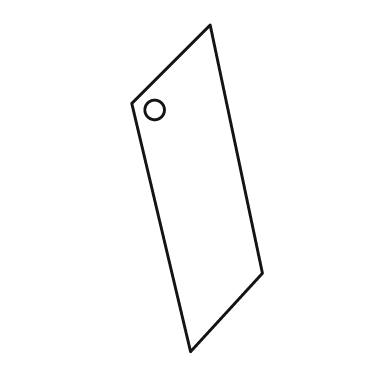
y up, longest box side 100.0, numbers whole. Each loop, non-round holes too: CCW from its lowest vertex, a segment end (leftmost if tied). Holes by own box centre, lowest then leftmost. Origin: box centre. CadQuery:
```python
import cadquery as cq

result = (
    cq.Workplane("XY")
    .moveTo(-2.0, -50.0)
    .lineTo(20.0, -26.0)
    .lineTo(4.0, 50.0)
    .lineTo(-20.0, 26.0)
    .close()
    .moveTo(-13.0, 24.0)
    .circle(3.0)
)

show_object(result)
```